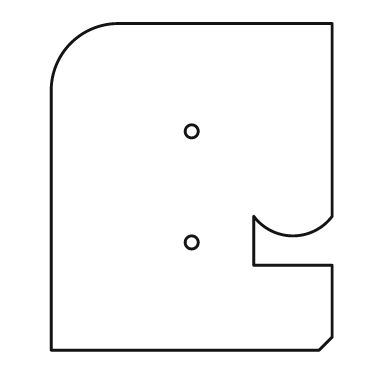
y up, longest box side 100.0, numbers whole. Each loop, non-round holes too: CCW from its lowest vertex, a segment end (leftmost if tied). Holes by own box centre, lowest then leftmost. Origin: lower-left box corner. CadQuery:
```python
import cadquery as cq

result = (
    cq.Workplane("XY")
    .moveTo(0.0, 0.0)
    .lineTo(82.0, 0.0)
    .lineTo(86.0, 4.0)
    .lineTo(86.0, 26.0)
    .lineTo(62.0, 26.0)
    .lineTo(62.0, 41.0)
    .threePointArc((74.0, 35.0), (86.0, 41.0))
    .lineTo(86.0, 100.0)
    .lineTo(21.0, 100.0)
    .threePointArc((6.0, 94.0), (0.0, 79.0))
    .close()
    .moveTo(43.0, 33.0)
    .circle(2.0)
    .moveTo(43.0, 67.0)
    .circle(2.0)
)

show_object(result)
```